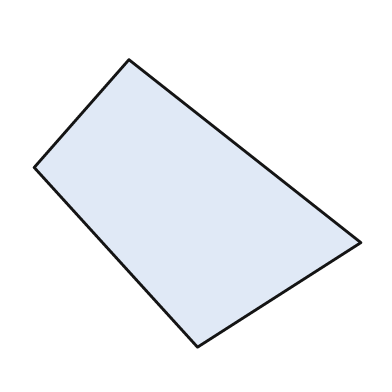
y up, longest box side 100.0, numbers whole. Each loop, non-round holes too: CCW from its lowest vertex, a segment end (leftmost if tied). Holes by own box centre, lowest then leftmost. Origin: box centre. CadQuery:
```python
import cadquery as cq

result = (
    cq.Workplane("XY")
    .moveTo(0.0, -44.0)
    .lineTo(50.0, -12.0)
    .lineTo(-21.0, 44.0)
    .lineTo(-50.0, 11.0)
    .close()
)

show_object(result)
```